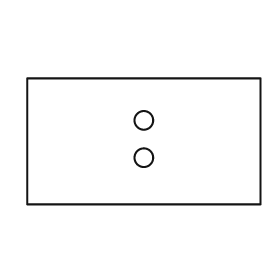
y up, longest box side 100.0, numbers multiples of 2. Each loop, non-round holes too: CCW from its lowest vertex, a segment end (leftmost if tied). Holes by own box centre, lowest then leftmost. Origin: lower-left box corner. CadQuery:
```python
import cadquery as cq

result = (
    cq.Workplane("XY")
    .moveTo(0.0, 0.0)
    .lineTo(100.0, 0.0)
    .lineTo(100.0, 54.0)
    .lineTo(0.0, 54.0)
    .close()
    .moveTo(50.0, 20.0)
    .circle(4.0)
    .moveTo(50.0, 36.0)
    .circle(4.0)
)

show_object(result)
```